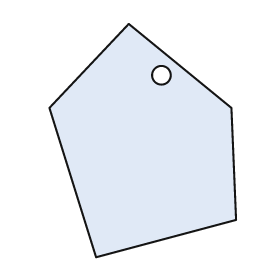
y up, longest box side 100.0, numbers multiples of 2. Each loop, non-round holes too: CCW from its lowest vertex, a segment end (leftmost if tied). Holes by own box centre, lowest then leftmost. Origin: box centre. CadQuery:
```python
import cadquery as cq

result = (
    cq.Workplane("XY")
    .moveTo(-20.0, -50.0)
    .lineTo(40.0, -34.0)
    .lineTo(38.0, 14.0)
    .lineTo(-6.0, 50.0)
    .lineTo(-40.0, 14.0)
    .close()
    .moveTo(8.0, 28.0)
    .circle(4.0)
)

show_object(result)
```